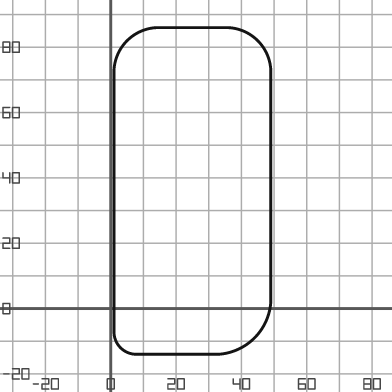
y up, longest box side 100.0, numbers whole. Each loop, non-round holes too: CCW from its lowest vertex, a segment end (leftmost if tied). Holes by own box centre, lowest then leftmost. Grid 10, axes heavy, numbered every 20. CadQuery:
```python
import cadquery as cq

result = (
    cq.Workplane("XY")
    .moveTo(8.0, -14.0)
    .lineTo(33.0, -14.0)
    .threePointArc((44.0, -9.0), (49.0, 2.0))
    .lineTo(49.0, 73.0)
    .threePointArc((45.0, 82.0), (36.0, 86.0))
    .lineTo(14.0, 86.0)
    .threePointArc((5.0, 82.0), (1.0, 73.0))
    .lineTo(1.0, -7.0)
    .threePointArc((3.0, -12.0), (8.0, -14.0))
    .close()
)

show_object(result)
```